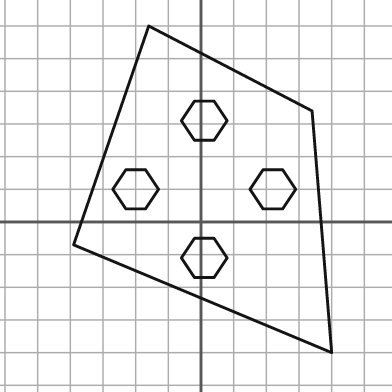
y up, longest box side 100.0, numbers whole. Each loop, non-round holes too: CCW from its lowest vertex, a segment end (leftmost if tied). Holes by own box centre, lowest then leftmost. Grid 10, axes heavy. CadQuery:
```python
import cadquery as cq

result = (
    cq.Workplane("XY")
    .moveTo(40.0, -40.0)
    .lineTo(34.0, 34.0)
    .lineTo(-16.0, 60.0)
    .lineTo(-39.0, -7.0)
    .close()
    .moveTo(-2.0, -17.0)
    .lineTo(4.0, -17.0)
    .lineTo(8.0, -11.0)
    .lineTo(4.0, -5.0)
    .lineTo(-2.0, -5.0)
    .lineTo(-6.0, -11.0)
    .close()
    .moveTo(-23.0, 4.0)
    .lineTo(-17.0, 4.0)
    .lineTo(-13.0, 10.0)
    .lineTo(-17.0, 16.0)
    .lineTo(-23.0, 16.0)
    .lineTo(-27.0, 10.0)
    .close()
    .moveTo(19.0, 4.0)
    .lineTo(25.0, 4.0)
    .lineTo(29.0, 10.0)
    .lineTo(25.0, 16.0)
    .lineTo(19.0, 16.0)
    .lineTo(15.0, 10.0)
    .close()
    .moveTo(-2.0, 25.0)
    .lineTo(4.0, 25.0)
    .lineTo(8.0, 31.0)
    .lineTo(4.0, 37.0)
    .lineTo(-2.0, 37.0)
    .lineTo(-6.0, 31.0)
    .close()
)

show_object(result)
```